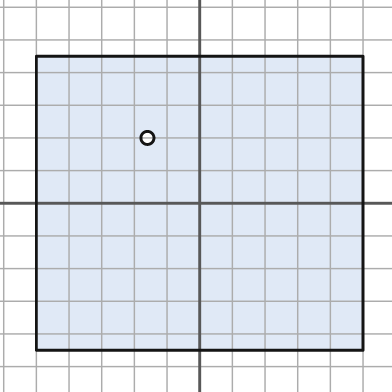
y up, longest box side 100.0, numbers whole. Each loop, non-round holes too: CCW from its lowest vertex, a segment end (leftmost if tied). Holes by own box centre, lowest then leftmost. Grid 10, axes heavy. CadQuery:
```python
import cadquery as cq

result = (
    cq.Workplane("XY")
    .moveTo(-50.0, -45.0)
    .lineTo(50.0, -45.0)
    .lineTo(50.0, 45.0)
    .lineTo(-50.0, 45.0)
    .close()
    .moveTo(-16.0, 20.0)
    .circle(2.0)
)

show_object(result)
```